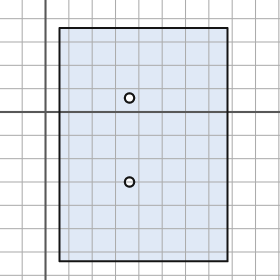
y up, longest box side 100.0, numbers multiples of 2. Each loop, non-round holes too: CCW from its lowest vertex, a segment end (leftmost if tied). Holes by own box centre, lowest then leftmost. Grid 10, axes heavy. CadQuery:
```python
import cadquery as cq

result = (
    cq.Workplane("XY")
    .moveTo(6.0, -64.0)
    .lineTo(78.0, -64.0)
    .lineTo(78.0, 36.0)
    .lineTo(6.0, 36.0)
    .close()
    .moveTo(36.0, -30.0)
    .circle(2.0)
    .moveTo(36.0, 6.0)
    .circle(2.0)
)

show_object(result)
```